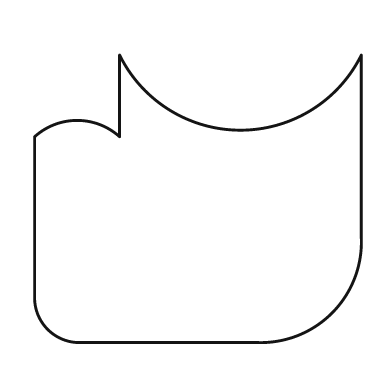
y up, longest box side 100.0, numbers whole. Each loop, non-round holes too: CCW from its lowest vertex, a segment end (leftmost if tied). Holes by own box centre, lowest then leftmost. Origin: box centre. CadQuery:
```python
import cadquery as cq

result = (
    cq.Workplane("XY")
    .moveTo(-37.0, -44.0)
    .lineTo(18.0, -44.0)
    .threePointArc((41.0, -35.0), (50.0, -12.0))
    .lineTo(50.0, 44.0)
    .threePointArc((13.0, 21.0), (-24.0, 44.0))
    .lineTo(-24.0, 19.0)
    .threePointArc((-37.0, 24.0), (-50.0, 19.0))
    .lineTo(-50.0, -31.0)
    .threePointArc((-46.0, -40.0), (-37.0, -44.0))
    .close()
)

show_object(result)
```